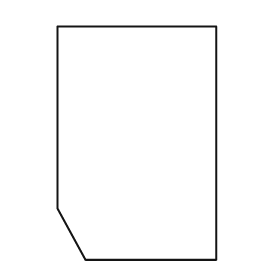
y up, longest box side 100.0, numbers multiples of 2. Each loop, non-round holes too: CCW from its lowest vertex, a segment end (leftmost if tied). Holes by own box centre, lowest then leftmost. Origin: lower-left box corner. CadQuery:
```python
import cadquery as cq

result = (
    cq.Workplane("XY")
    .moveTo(12.0, 0.0)
    .lineTo(68.0, 0.0)
    .lineTo(68.0, 100.0)
    .lineTo(0.0, 100.0)
    .lineTo(0.0, 22.0)
    .close()
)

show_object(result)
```